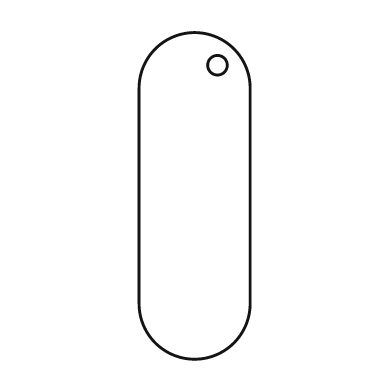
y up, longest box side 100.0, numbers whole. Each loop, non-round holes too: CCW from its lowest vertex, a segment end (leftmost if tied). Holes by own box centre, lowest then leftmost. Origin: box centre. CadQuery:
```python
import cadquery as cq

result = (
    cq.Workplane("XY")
    .moveTo(-17.0, -33.0)
    .threePointArc((0.0, -50.0), (17.0, -33.0))
    .lineTo(17.0, 33.0)
    .threePointArc((0.0, 50.0), (-17.0, 33.0))
    .close()
    .moveTo(7.0, 40.0)
    .circle(3.0)
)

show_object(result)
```